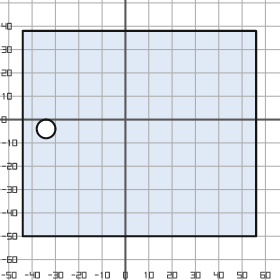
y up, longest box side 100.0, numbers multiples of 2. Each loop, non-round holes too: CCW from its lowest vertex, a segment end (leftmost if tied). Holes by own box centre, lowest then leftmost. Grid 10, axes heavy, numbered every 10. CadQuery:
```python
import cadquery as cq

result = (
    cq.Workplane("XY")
    .moveTo(-44.0, -50.0)
    .lineTo(56.0, -50.0)
    .lineTo(56.0, 38.0)
    .lineTo(-44.0, 38.0)
    .close()
    .moveTo(-34.0, -4.0)
    .circle(4.0)
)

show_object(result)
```